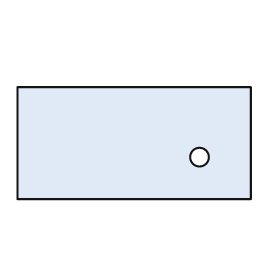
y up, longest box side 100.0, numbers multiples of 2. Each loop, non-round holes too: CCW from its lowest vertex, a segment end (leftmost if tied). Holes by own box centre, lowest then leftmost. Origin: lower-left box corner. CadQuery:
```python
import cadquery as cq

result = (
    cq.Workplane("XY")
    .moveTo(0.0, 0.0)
    .lineTo(100.0, 0.0)
    .lineTo(100.0, 48.0)
    .lineTo(0.0, 48.0)
    .close()
    .moveTo(78.0, 18.0)
    .circle(4.0)
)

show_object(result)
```